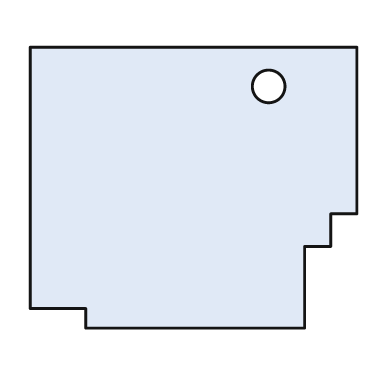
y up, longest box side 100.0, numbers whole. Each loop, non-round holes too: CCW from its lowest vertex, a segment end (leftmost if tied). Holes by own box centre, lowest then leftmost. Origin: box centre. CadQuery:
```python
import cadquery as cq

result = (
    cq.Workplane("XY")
    .moveTo(-33.0, -43.0)
    .lineTo(34.0, -43.0)
    .lineTo(34.0, -18.0)
    .lineTo(42.0, -18.0)
    .lineTo(42.0, -8.0)
    .lineTo(50.0, -8.0)
    .lineTo(50.0, 43.0)
    .lineTo(-50.0, 43.0)
    .lineTo(-50.0, -37.0)
    .lineTo(-33.0, -37.0)
    .close()
    .moveTo(23.0, 31.0)
    .circle(5.0)
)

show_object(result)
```